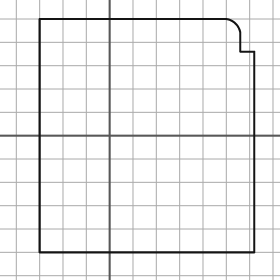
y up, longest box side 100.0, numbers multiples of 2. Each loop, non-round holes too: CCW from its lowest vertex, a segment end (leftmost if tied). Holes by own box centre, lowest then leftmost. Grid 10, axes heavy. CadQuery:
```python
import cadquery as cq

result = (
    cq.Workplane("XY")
    .moveTo(-30.0, -50.0)
    .lineTo(62.0, -50.0)
    .lineTo(62.0, 36.0)
    .lineTo(56.0, 36.0)
    .lineTo(56.0, 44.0)
    .threePointArc((54.0, 48.0), (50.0, 50.0))
    .lineTo(-30.0, 50.0)
    .close()
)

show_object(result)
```